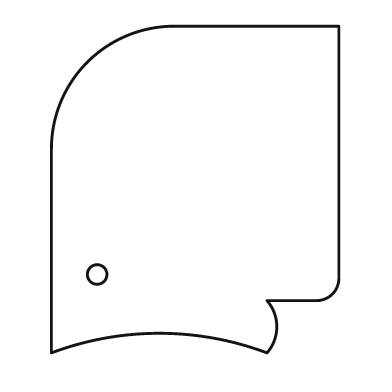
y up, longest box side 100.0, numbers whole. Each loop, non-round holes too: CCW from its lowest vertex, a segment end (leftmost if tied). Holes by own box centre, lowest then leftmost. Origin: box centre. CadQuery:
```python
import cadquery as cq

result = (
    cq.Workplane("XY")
    .moveTo(-44.0, -50.0)
    .threePointArc((-11.0, -44.0), (22.0, -50.0))
    .threePointArc((25.0, -42.0), (22.0, -34.0))
    .lineTo(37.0, -34.0)
    .threePointArc((42.0, -32.0), (44.0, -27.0))
    .lineTo(44.0, 50.0)
    .lineTo(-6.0, 50.0)
    .threePointArc((-33.0, 39.0), (-44.0, 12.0))
    .close()
    .moveTo(-30.0, -26.0)
    .circle(3.0)
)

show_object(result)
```